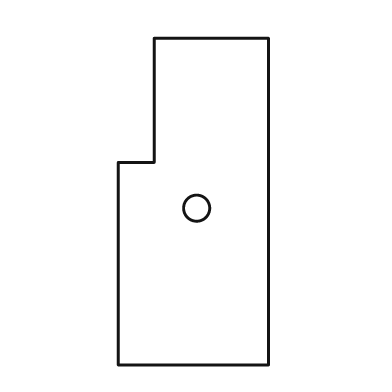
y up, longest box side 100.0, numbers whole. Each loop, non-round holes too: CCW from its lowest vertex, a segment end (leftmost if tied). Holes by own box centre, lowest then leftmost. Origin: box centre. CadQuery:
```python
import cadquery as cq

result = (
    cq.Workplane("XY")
    .moveTo(-23.0, -50.0)
    .lineTo(23.0, -50.0)
    .lineTo(23.0, 50.0)
    .lineTo(-12.0, 50.0)
    .lineTo(-12.0, 12.0)
    .lineTo(-23.0, 12.0)
    .close()
    .moveTo(1.0, -2.0)
    .circle(4.0)
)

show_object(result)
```